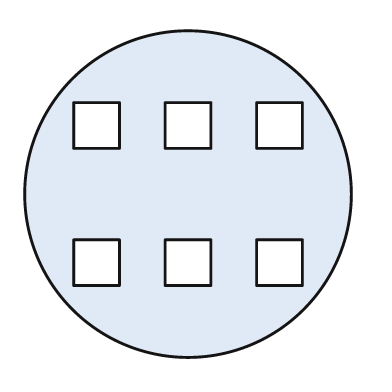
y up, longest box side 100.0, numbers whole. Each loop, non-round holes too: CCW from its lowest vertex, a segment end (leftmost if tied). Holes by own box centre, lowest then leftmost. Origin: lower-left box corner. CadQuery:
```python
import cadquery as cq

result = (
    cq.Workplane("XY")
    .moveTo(50.0, 50.0)
    .circle(50.0)
    .moveTo(15.0, 22.0)
    .lineTo(29.0, 22.0)
    .lineTo(29.0, 36.0)
    .lineTo(15.0, 36.0)
    .close()
    .moveTo(43.0, 22.0)
    .lineTo(57.0, 22.0)
    .lineTo(57.0, 36.0)
    .lineTo(43.0, 36.0)
    .close()
    .moveTo(71.0, 22.0)
    .lineTo(85.0, 22.0)
    .lineTo(85.0, 36.0)
    .lineTo(71.0, 36.0)
    .close()
    .moveTo(15.0, 64.0)
    .lineTo(29.0, 64.0)
    .lineTo(29.0, 78.0)
    .lineTo(15.0, 78.0)
    .close()
    .moveTo(43.0, 64.0)
    .lineTo(57.0, 64.0)
    .lineTo(57.0, 78.0)
    .lineTo(43.0, 78.0)
    .close()
    .moveTo(71.0, 64.0)
    .lineTo(85.0, 64.0)
    .lineTo(85.0, 78.0)
    .lineTo(71.0, 78.0)
    .close()
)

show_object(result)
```